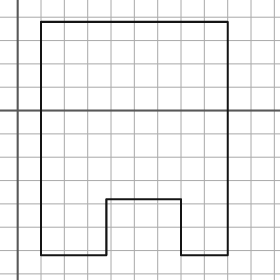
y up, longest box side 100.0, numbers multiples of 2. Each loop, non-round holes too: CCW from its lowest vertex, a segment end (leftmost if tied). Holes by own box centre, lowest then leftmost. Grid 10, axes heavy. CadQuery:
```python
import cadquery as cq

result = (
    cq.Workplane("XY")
    .moveTo(10.0, -62.0)
    .lineTo(38.0, -62.0)
    .lineTo(38.0, -38.0)
    .lineTo(70.0, -38.0)
    .lineTo(70.0, -62.0)
    .lineTo(90.0, -62.0)
    .lineTo(90.0, 38.0)
    .lineTo(10.0, 38.0)
    .close()
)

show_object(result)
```